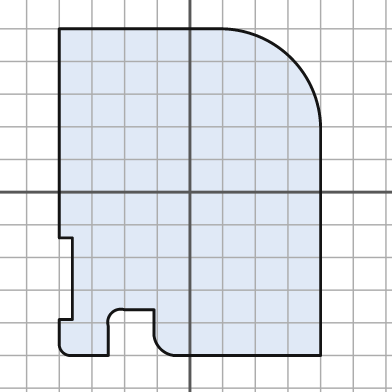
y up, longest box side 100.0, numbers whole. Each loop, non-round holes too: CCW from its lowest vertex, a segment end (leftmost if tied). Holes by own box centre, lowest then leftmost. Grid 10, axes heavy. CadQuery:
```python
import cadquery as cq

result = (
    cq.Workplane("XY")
    .moveTo(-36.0, -50.0)
    .lineTo(-25.0, -50.0)
    .lineTo(-25.0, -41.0)
    .threePointArc((-24.0, -37.0), (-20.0, -36.0))
    .lineTo(-11.0, -36.0)
    .lineTo(-11.0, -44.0)
    .threePointArc((-9.0, -48.0), (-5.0, -50.0))
    .lineTo(40.0, -50.0)
    .lineTo(40.0, 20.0)
    .threePointArc((31.0, 41.0), (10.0, 50.0))
    .lineTo(-40.0, 50.0)
    .lineTo(-40.0, -14.0)
    .lineTo(-36.0, -14.0)
    .lineTo(-36.0, -39.0)
    .lineTo(-40.0, -39.0)
    .lineTo(-40.0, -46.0)
    .threePointArc((-39.0, -49.0), (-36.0, -50.0))
    .close()
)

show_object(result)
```